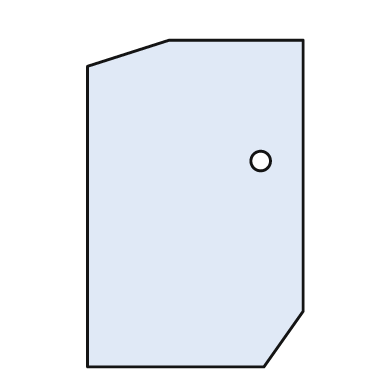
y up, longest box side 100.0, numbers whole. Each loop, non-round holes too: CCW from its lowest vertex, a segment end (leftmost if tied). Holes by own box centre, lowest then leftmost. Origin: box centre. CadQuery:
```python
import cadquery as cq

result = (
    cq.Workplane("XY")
    .moveTo(-33.0, -50.0)
    .lineTo(21.0, -50.0)
    .lineTo(33.0, -33.0)
    .lineTo(33.0, 50.0)
    .lineTo(-8.0, 50.0)
    .lineTo(-33.0, 42.0)
    .close()
    .moveTo(20.0, 13.0)
    .circle(3.0)
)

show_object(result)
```